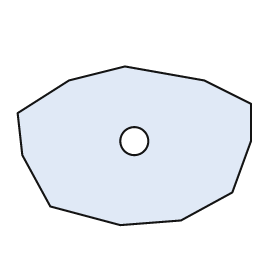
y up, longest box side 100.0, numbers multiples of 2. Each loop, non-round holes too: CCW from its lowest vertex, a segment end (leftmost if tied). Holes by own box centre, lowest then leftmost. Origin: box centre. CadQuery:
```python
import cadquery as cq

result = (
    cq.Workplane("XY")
    .moveTo(-6.0, -34.0)
    .lineTo(20.0, -32.0)
    .lineTo(42.0, -20.0)
    .lineTo(50.0, 2.0)
    .lineTo(50.0, 18.0)
    .lineTo(30.0, 28.0)
    .lineTo(-4.0, 34.0)
    .lineTo(-28.0, 28.0)
    .lineTo(-50.0, 14.0)
    .lineTo(-48.0, -4.0)
    .lineTo(-36.0, -26.0)
    .close()
    .moveTo(0.0, 2.0)
    .circle(6.0)
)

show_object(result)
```